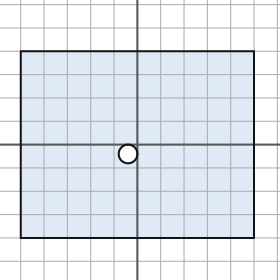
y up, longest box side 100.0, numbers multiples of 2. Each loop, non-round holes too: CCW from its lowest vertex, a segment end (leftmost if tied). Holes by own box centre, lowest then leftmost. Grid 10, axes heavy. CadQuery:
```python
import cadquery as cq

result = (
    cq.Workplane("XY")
    .moveTo(-50.0, -40.0)
    .lineTo(50.0, -40.0)
    .lineTo(50.0, 40.0)
    .lineTo(-50.0, 40.0)
    .close()
    .moveTo(-4.0, -4.0)
    .circle(4.0)
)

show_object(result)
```